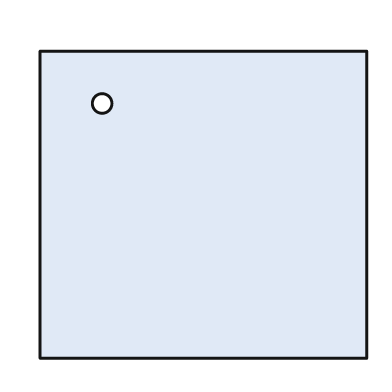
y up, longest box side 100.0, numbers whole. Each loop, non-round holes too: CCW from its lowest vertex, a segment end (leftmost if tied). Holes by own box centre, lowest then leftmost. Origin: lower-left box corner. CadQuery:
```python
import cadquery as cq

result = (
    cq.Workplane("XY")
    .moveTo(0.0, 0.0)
    .lineTo(100.0, 0.0)
    .lineTo(100.0, 94.0)
    .lineTo(0.0, 94.0)
    .close()
    .moveTo(19.0, 78.0)
    .circle(3.0)
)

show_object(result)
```